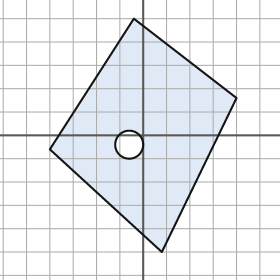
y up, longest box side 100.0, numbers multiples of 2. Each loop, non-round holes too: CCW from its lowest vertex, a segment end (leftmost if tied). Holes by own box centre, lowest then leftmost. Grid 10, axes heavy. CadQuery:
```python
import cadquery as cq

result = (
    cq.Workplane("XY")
    .moveTo(8.0, -50.0)
    .lineTo(40.0, 16.0)
    .lineTo(-4.0, 50.0)
    .lineTo(-40.0, -6.0)
    .close()
    .moveTo(-6.0, -4.0)
    .circle(6.0)
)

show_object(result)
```